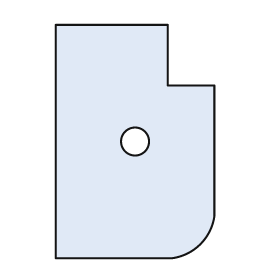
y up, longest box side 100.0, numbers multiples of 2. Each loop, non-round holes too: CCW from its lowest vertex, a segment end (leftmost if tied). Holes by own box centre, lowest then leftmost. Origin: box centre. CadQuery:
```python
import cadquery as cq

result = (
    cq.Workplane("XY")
    .moveTo(-34.0, -50.0)
    .lineTo(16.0, -50.0)
    .threePointArc((28.0, -44.0), (34.0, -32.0))
    .lineTo(34.0, 24.0)
    .lineTo(14.0, 24.0)
    .lineTo(14.0, 50.0)
    .lineTo(-34.0, 50.0)
    .close()
    .moveTo(0.0, 0.0)
    .circle(6.0)
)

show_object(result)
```